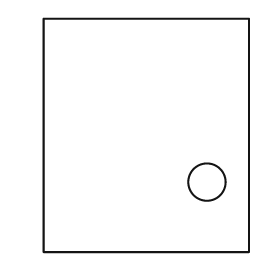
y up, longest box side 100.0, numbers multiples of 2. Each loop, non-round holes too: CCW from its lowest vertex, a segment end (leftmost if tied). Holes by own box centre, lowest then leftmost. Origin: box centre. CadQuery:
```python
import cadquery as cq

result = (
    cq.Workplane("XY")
    .moveTo(-44.0, -50.0)
    .lineTo(44.0, -50.0)
    .lineTo(44.0, 50.0)
    .lineTo(-44.0, 50.0)
    .close()
    .moveTo(26.0, -20.0)
    .circle(8.0)
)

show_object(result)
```